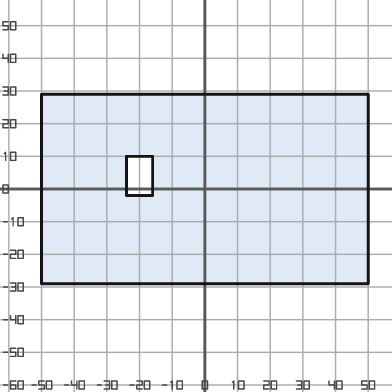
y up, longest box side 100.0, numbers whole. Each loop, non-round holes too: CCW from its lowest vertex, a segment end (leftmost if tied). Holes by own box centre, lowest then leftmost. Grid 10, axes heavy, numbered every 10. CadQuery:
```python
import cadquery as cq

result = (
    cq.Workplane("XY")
    .moveTo(-50.0, -29.0)
    .lineTo(50.0, -29.0)
    .lineTo(50.0, 29.0)
    .lineTo(-50.0, 29.0)
    .close()
    .moveTo(-24.0, -2.0)
    .lineTo(-16.0, -2.0)
    .lineTo(-16.0, 10.0)
    .lineTo(-24.0, 10.0)
    .close()
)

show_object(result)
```